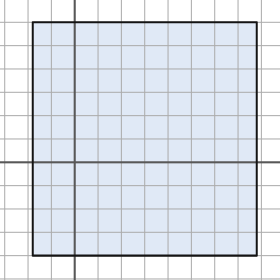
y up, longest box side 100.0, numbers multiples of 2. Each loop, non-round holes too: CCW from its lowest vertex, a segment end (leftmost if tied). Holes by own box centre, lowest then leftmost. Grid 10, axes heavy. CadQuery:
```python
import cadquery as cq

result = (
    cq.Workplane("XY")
    .moveTo(-18.0, -40.0)
    .lineTo(78.0, -40.0)
    .lineTo(78.0, 60.0)
    .lineTo(-18.0, 60.0)
    .close()
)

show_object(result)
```